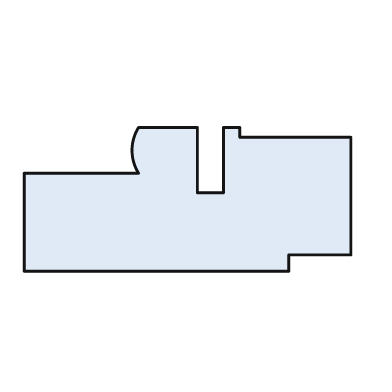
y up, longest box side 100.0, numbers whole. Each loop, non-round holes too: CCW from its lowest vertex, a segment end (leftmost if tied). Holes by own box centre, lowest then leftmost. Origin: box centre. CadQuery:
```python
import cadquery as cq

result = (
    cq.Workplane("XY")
    .moveTo(-50.0, -22.0)
    .lineTo(31.0, -22.0)
    .lineTo(31.0, -17.0)
    .lineTo(50.0, -17.0)
    .lineTo(50.0, 19.0)
    .lineTo(16.0, 19.0)
    .lineTo(16.0, 22.0)
    .lineTo(11.0, 22.0)
    .lineTo(11.0, 2.0)
    .lineTo(3.0, 2.0)
    .lineTo(3.0, 22.0)
    .lineTo(-15.0, 22.0)
    .threePointArc((-17.0, 15.0), (-15.0, 8.0))
    .lineTo(-50.0, 8.0)
    .close()
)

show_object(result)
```